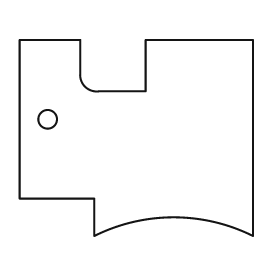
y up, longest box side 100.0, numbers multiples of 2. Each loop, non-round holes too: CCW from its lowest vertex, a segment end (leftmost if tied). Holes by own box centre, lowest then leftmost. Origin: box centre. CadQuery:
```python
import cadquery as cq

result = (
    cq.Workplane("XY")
    .moveTo(-18.0, -42.0)
    .threePointArc((16.0, -34.0), (50.0, -42.0))
    .lineTo(50.0, 42.0)
    .lineTo(4.0, 42.0)
    .lineTo(4.0, 20.0)
    .lineTo(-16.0, 20.0)
    .threePointArc((-22.0, 22.0), (-24.0, 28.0))
    .lineTo(-24.0, 42.0)
    .lineTo(-50.0, 42.0)
    .lineTo(-50.0, -26.0)
    .lineTo(-18.0, -26.0)
    .close()
    .moveTo(-38.0, 8.0)
    .circle(4.0)
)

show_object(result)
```